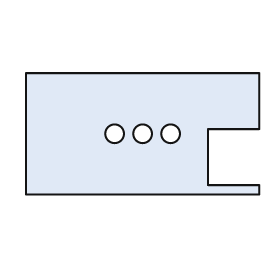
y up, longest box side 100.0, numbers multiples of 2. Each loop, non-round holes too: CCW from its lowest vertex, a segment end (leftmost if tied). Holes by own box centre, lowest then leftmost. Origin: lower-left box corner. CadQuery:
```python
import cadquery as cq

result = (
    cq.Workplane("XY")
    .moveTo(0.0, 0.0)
    .lineTo(100.0, 0.0)
    .lineTo(100.0, 4.0)
    .lineTo(78.0, 4.0)
    .lineTo(78.0, 28.0)
    .lineTo(100.0, 28.0)
    .lineTo(100.0, 52.0)
    .lineTo(0.0, 52.0)
    .close()
    .moveTo(38.0, 26.0)
    .circle(4.0)
    .moveTo(50.0, 26.0)
    .circle(4.0)
    .moveTo(62.0, 26.0)
    .circle(4.0)
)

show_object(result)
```